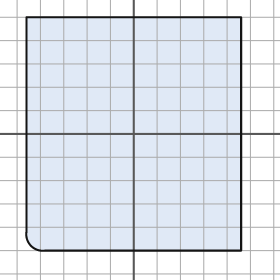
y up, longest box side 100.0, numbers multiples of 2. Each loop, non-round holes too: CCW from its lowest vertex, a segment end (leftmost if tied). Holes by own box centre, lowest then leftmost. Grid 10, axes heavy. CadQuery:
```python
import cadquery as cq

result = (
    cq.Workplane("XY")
    .moveTo(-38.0, -50.0)
    .lineTo(46.0, -50.0)
    .lineTo(46.0, 50.0)
    .lineTo(-46.0, 50.0)
    .lineTo(-46.0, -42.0)
    .threePointArc((-44.0, -48.0), (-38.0, -50.0))
    .close()
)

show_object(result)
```